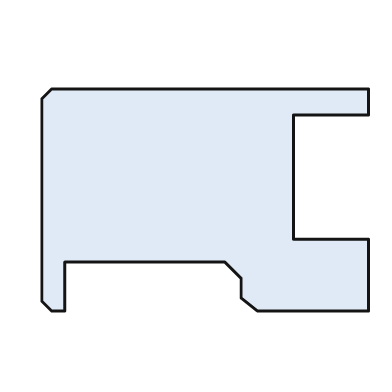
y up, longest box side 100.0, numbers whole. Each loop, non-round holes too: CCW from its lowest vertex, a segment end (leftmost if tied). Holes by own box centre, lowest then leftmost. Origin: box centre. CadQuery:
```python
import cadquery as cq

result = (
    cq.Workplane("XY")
    .moveTo(-47.0, -34.0)
    .lineTo(-43.0, -34.0)
    .lineTo(-43.0, -19.0)
    .lineTo(6.0, -19.0)
    .lineTo(11.0, -24.0)
    .lineTo(11.0, -30.0)
    .lineTo(16.0, -34.0)
    .lineTo(50.0, -34.0)
    .lineTo(50.0, -12.0)
    .lineTo(27.0, -12.0)
    .lineTo(27.0, 26.0)
    .lineTo(50.0, 26.0)
    .lineTo(50.0, 34.0)
    .lineTo(-47.0, 34.0)
    .lineTo(-50.0, 31.0)
    .lineTo(-50.0, -31.0)
    .close()
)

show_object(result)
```